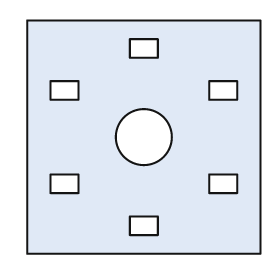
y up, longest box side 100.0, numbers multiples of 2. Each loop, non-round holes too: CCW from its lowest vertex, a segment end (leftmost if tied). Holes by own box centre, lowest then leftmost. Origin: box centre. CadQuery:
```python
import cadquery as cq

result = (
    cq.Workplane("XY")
    .moveTo(-50.0, -50.0)
    .lineTo(50.0, -50.0)
    .lineTo(50.0, 50.0)
    .lineTo(-50.0, 50.0)
    .close()
    .moveTo(-6.0, -42.0)
    .lineTo(6.0, -42.0)
    .lineTo(6.0, -34.0)
    .lineTo(-6.0, -34.0)
    .close()
    .moveTo(-40.0, -24.0)
    .lineTo(-28.0, -24.0)
    .lineTo(-28.0, -16.0)
    .lineTo(-40.0, -16.0)
    .close()
    .moveTo(28.0, -24.0)
    .lineTo(40.0, -24.0)
    .lineTo(40.0, -16.0)
    .lineTo(28.0, -16.0)
    .close()
    .moveTo(0.0, 0.0)
    .circle(12.0)
    .moveTo(-40.0, 16.0)
    .lineTo(-28.0, 16.0)
    .lineTo(-28.0, 24.0)
    .lineTo(-40.0, 24.0)
    .close()
    .moveTo(28.0, 16.0)
    .lineTo(40.0, 16.0)
    .lineTo(40.0, 24.0)
    .lineTo(28.0, 24.0)
    .close()
    .moveTo(-6.0, 34.0)
    .lineTo(6.0, 34.0)
    .lineTo(6.0, 42.0)
    .lineTo(-6.0, 42.0)
    .close()
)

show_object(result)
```